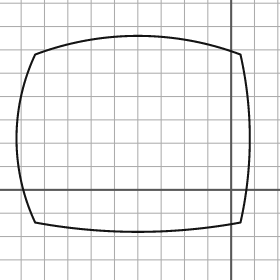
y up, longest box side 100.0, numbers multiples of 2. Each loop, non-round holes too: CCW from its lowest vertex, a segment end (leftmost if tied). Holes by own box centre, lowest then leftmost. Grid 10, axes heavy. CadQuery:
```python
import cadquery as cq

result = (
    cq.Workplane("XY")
    .moveTo(-84.0, -14.0)
    .threePointArc((-40.0, -18.0), (4.0, -14.0))
    .threePointArc((8.0, 22.0), (4.0, 58.0))
    .threePointArc((-40.0, 66.0), (-84.0, 58.0))
    .threePointArc((-92.0, 22.0), (-84.0, -14.0))
    .close()
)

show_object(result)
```